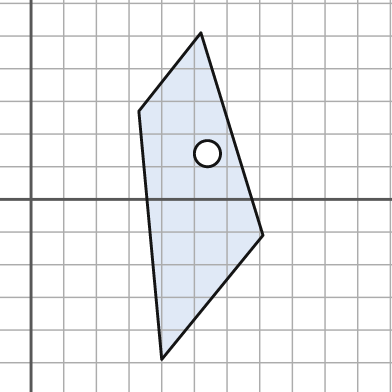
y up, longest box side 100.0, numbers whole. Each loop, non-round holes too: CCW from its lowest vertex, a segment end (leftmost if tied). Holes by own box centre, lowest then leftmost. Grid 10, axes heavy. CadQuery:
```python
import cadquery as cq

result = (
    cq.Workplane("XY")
    .moveTo(40.0, -49.0)
    .lineTo(71.0, -11.0)
    .lineTo(52.0, 51.0)
    .lineTo(33.0, 27.0)
    .close()
    .moveTo(54.0, 14.0)
    .circle(4.0)
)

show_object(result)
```